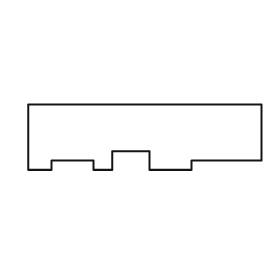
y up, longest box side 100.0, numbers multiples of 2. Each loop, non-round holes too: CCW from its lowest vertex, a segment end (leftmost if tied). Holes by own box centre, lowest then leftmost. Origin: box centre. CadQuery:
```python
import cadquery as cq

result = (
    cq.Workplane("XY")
    .moveTo(-50.0, -14.0)
    .lineTo(-40.0, -14.0)
    .lineTo(-40.0, -10.0)
    .lineTo(-22.0, -10.0)
    .lineTo(-22.0, -14.0)
    .lineTo(-14.0, -14.0)
    .lineTo(-14.0, -6.0)
    .lineTo(2.0, -6.0)
    .lineTo(2.0, -14.0)
    .lineTo(20.0, -14.0)
    .lineTo(20.0, -10.0)
    .lineTo(50.0, -10.0)
    .lineTo(50.0, 14.0)
    .lineTo(-50.0, 14.0)
    .close()
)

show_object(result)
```